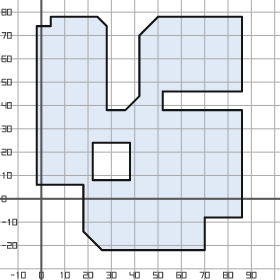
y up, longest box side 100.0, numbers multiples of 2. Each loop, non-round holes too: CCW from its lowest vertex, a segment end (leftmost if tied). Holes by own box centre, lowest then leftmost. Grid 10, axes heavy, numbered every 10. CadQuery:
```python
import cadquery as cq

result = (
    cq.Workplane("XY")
    .moveTo(26.0, -22.0)
    .lineTo(70.0, -22.0)
    .lineTo(70.0, -8.0)
    .lineTo(86.0, -8.0)
    .lineTo(86.0, 38.0)
    .lineTo(52.0, 38.0)
    .lineTo(52.0, 46.0)
    .lineTo(86.0, 46.0)
    .lineTo(86.0, 78.0)
    .lineTo(50.0, 78.0)
    .lineTo(42.0, 70.0)
    .lineTo(42.0, 44.0)
    .lineTo(36.0, 38.0)
    .lineTo(28.0, 38.0)
    .lineTo(28.0, 74.0)
    .lineTo(24.0, 78.0)
    .lineTo(4.0, 78.0)
    .lineTo(4.0, 74.0)
    .lineTo(-2.0, 74.0)
    .lineTo(-2.0, 6.0)
    .lineTo(18.0, 6.0)
    .lineTo(18.0, -14.0)
    .close()
    .moveTo(22.0, 8.0)
    .lineTo(38.0, 8.0)
    .lineTo(38.0, 24.0)
    .lineTo(22.0, 24.0)
    .close()
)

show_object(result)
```